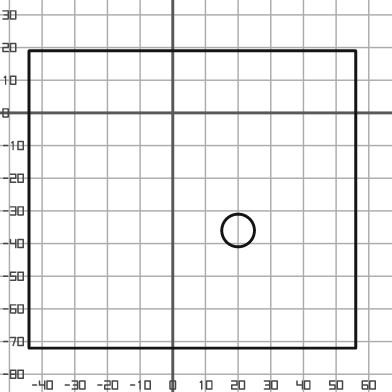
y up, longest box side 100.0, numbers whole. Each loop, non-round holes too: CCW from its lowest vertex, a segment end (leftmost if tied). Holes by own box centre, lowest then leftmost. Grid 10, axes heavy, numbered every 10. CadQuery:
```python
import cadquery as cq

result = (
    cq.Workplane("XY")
    .moveTo(-44.0, -72.0)
    .lineTo(56.0, -72.0)
    .lineTo(56.0, 19.0)
    .lineTo(-44.0, 19.0)
    .close()
    .moveTo(20.0, -36.0)
    .circle(5.0)
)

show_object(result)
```